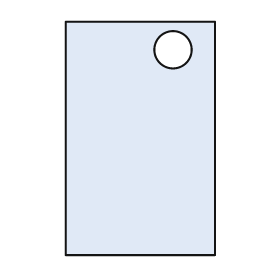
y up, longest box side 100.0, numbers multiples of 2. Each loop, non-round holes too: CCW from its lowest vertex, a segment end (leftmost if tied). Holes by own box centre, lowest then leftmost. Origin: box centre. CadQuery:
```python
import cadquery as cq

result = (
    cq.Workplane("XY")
    .moveTo(-32.0, -50.0)
    .lineTo(32.0, -50.0)
    .lineTo(32.0, 50.0)
    .lineTo(-32.0, 50.0)
    .close()
    .moveTo(14.0, 38.0)
    .circle(8.0)
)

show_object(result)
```